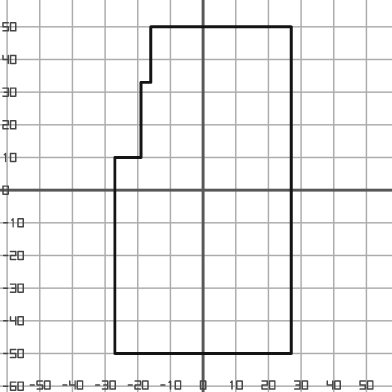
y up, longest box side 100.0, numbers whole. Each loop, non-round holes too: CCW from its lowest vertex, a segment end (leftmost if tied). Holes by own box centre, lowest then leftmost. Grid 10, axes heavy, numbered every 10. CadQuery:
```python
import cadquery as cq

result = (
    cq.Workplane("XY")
    .moveTo(-27.0, -50.0)
    .lineTo(27.0, -50.0)
    .lineTo(27.0, 50.0)
    .lineTo(-16.0, 50.0)
    .lineTo(-16.0, 33.0)
    .lineTo(-19.0, 33.0)
    .lineTo(-19.0, 10.0)
    .lineTo(-27.0, 10.0)
    .close()
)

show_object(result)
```